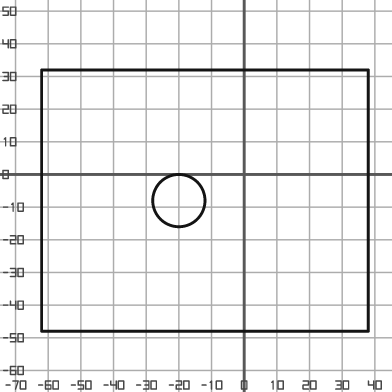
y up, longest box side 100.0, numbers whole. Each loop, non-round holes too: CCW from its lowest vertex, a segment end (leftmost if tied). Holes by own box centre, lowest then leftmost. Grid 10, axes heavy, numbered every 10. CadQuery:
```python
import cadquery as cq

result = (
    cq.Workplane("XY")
    .moveTo(-62.0, -48.0)
    .lineTo(38.0, -48.0)
    .lineTo(38.0, 32.0)
    .lineTo(-62.0, 32.0)
    .close()
    .moveTo(-20.0, -8.0)
    .circle(8.0)
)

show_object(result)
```